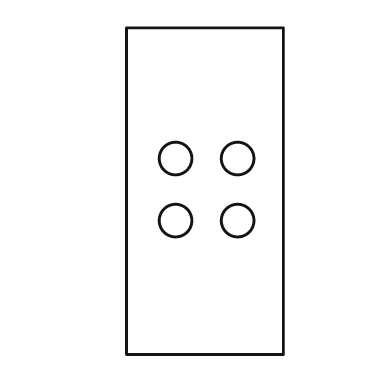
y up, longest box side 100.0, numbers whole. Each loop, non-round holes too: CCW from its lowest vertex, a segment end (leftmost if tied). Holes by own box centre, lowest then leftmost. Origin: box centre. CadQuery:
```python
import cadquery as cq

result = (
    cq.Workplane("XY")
    .moveTo(-24.0, -50.0)
    .lineTo(24.0, -50.0)
    .lineTo(24.0, 50.0)
    .lineTo(-24.0, 50.0)
    .close()
    .moveTo(-9.0, -9.0)
    .circle(5.0)
    .moveTo(10.0, -9.0)
    .circle(5.0)
    .moveTo(-9.0, 10.0)
    .circle(5.0)
    .moveTo(10.0, 10.0)
    .circle(5.0)
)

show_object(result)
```